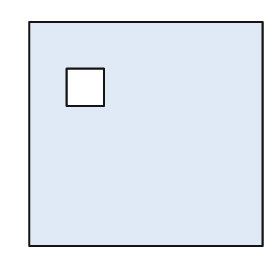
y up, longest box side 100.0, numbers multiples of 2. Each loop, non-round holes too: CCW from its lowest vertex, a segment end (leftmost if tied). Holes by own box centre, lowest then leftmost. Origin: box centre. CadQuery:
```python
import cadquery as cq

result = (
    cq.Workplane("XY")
    .moveTo(-50.0, -48.0)
    .lineTo(50.0, -48.0)
    .lineTo(50.0, 48.0)
    .lineTo(-50.0, 48.0)
    .close()
    .moveTo(-34.0, 12.0)
    .lineTo(-18.0, 12.0)
    .lineTo(-18.0, 28.0)
    .lineTo(-34.0, 28.0)
    .close()
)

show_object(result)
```